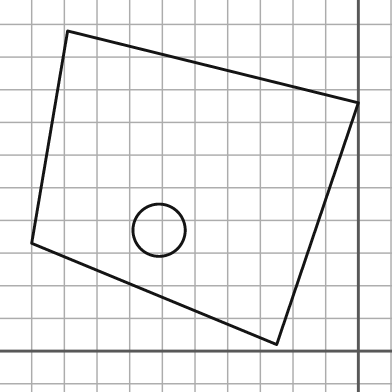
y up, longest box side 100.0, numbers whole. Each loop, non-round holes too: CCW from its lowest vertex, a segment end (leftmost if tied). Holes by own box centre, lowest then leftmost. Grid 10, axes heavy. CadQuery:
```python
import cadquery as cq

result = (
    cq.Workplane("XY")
    .moveTo(-25.0, 2.0)
    .lineTo(0.0, 76.0)
    .lineTo(-89.0, 98.0)
    .lineTo(-100.0, 33.0)
    .close()
    .moveTo(-61.0, 37.0)
    .circle(8.0)
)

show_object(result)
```